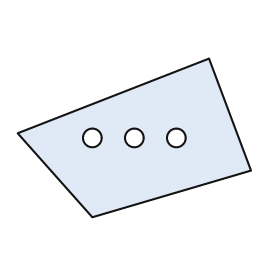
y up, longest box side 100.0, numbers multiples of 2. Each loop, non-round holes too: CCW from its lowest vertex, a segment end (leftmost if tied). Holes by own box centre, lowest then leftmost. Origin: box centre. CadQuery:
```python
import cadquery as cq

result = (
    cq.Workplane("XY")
    .moveTo(-18.0, -34.0)
    .lineTo(50.0, -14.0)
    .lineTo(32.0, 34.0)
    .lineTo(-50.0, 2.0)
    .close()
    .moveTo(-18.0, 0.0)
    .circle(4.0)
    .moveTo(0.0, 0.0)
    .circle(4.0)
    .moveTo(18.0, 0.0)
    .circle(4.0)
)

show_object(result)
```